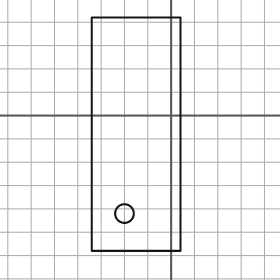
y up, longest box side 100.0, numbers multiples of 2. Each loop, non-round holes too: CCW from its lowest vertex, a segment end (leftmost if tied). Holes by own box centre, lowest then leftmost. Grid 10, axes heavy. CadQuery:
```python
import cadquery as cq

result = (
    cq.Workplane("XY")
    .moveTo(-34.0, -58.0)
    .lineTo(4.0, -58.0)
    .lineTo(4.0, 42.0)
    .lineTo(-34.0, 42.0)
    .close()
    .moveTo(-20.0, -42.0)
    .circle(4.0)
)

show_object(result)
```